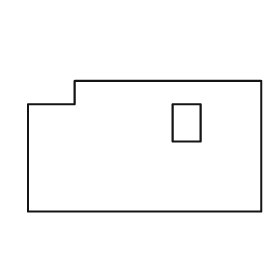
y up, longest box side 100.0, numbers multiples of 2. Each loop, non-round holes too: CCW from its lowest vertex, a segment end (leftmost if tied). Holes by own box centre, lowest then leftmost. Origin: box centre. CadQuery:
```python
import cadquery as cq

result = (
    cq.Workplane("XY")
    .moveTo(-50.0, -28.0)
    .lineTo(50.0, -28.0)
    .lineTo(50.0, 28.0)
    .lineTo(-30.0, 28.0)
    .lineTo(-30.0, 18.0)
    .lineTo(-50.0, 18.0)
    .close()
    .moveTo(12.0, 2.0)
    .lineTo(24.0, 2.0)
    .lineTo(24.0, 18.0)
    .lineTo(12.0, 18.0)
    .close()
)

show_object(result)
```